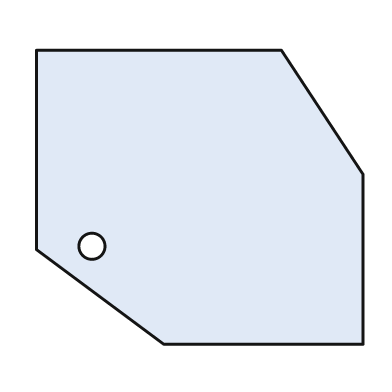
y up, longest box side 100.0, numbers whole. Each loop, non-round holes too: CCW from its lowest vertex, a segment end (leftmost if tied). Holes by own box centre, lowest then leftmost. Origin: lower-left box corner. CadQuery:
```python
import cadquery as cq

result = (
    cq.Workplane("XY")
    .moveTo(39.0, 0.0)
    .lineTo(100.0, 0.0)
    .lineTo(100.0, 52.0)
    .lineTo(75.0, 90.0)
    .lineTo(0.0, 90.0)
    .lineTo(0.0, 29.0)
    .close()
    .moveTo(17.0, 30.0)
    .circle(4.0)
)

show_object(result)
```